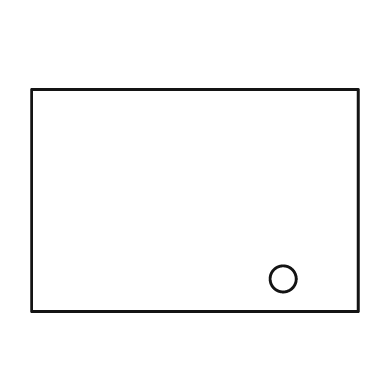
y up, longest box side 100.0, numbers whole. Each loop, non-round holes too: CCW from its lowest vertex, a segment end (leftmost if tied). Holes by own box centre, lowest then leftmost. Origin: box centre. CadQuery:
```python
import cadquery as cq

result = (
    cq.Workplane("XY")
    .moveTo(-50.0, -34.0)
    .lineTo(50.0, -34.0)
    .lineTo(50.0, 34.0)
    .lineTo(-50.0, 34.0)
    .close()
    .moveTo(27.0, -24.0)
    .circle(4.0)
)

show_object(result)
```